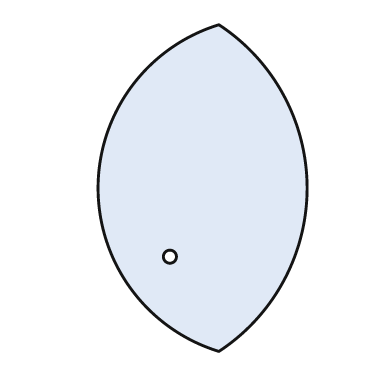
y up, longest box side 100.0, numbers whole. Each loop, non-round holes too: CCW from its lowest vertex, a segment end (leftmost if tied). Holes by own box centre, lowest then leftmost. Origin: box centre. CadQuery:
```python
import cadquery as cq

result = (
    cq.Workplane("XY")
    .moveTo(5.0, -50.0)
    .threePointArc((32.0, 0.0), (5.0, 50.0))
    .threePointArc((-32.0, 0.0), (5.0, -50.0))
    .close()
    .moveTo(-10.0, -21.0)
    .circle(2.0)
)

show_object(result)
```